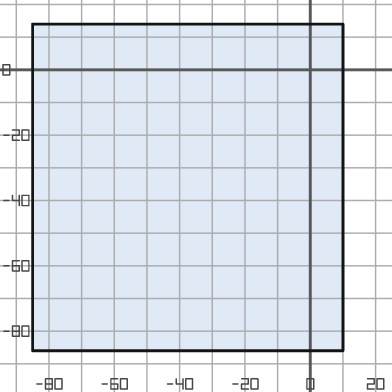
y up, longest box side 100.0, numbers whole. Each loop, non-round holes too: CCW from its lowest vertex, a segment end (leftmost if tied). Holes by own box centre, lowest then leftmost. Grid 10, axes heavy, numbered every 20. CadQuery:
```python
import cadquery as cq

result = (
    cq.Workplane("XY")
    .moveTo(-85.0, -86.0)
    .lineTo(10.0, -86.0)
    .lineTo(10.0, 14.0)
    .lineTo(-85.0, 14.0)
    .close()
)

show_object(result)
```